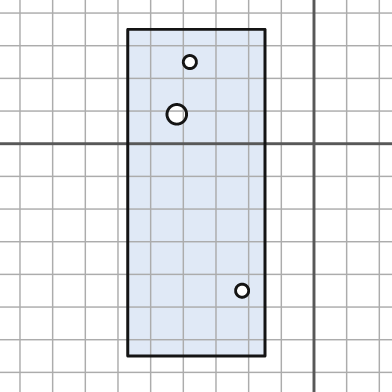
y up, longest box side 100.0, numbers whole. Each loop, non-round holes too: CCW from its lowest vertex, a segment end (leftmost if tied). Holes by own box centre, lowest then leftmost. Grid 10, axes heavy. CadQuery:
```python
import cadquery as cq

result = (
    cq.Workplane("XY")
    .moveTo(-57.0, -65.0)
    .lineTo(-15.0, -65.0)
    .lineTo(-15.0, 35.0)
    .lineTo(-57.0, 35.0)
    .close()
    .moveTo(-22.0, -45.0)
    .circle(2.0)
    .moveTo(-42.0, 9.0)
    .circle(3.0)
    .moveTo(-38.0, 25.0)
    .circle(2.0)
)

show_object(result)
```